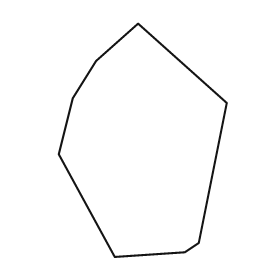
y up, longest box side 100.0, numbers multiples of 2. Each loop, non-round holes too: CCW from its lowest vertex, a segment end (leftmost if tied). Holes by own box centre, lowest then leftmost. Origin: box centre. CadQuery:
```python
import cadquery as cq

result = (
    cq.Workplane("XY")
    .moveTo(-12.0, -50.0)
    .lineTo(18.0, -48.0)
    .lineTo(24.0, -44.0)
    .lineTo(36.0, 16.0)
    .lineTo(-2.0, 50.0)
    .lineTo(-20.0, 34.0)
    .lineTo(-30.0, 18.0)
    .lineTo(-36.0, -6.0)
    .close()
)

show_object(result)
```